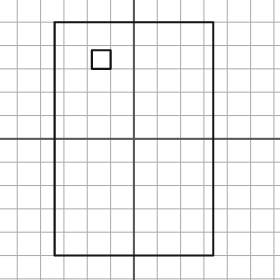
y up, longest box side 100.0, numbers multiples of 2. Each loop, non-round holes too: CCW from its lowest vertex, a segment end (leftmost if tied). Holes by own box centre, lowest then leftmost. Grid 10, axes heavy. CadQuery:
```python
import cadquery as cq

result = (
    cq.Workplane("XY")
    .moveTo(-34.0, -50.0)
    .lineTo(34.0, -50.0)
    .lineTo(34.0, 50.0)
    .lineTo(-34.0, 50.0)
    .close()
    .moveTo(-18.0, 30.0)
    .lineTo(-10.0, 30.0)
    .lineTo(-10.0, 38.0)
    .lineTo(-18.0, 38.0)
    .close()
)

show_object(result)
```